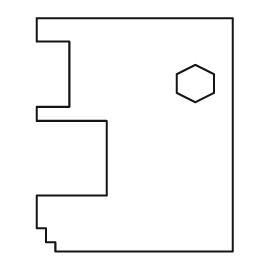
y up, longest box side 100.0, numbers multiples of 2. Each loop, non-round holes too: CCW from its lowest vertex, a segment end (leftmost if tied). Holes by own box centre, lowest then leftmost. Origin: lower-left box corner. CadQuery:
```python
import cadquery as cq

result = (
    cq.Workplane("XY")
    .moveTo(8.0, 0.0)
    .lineTo(84.0, 0.0)
    .lineTo(84.0, 100.0)
    .lineTo(0.0, 100.0)
    .lineTo(0.0, 90.0)
    .lineTo(14.0, 90.0)
    .lineTo(14.0, 62.0)
    .lineTo(0.0, 62.0)
    .lineTo(0.0, 56.0)
    .lineTo(30.0, 56.0)
    .lineTo(30.0, 24.0)
    .lineTo(0.0, 24.0)
    .lineTo(0.0, 10.0)
    .lineTo(4.0, 10.0)
    .lineTo(4.0, 4.0)
    .lineTo(8.0, 4.0)
    .close()
    .moveTo(68.0, 64.0)
    .lineTo(76.0, 68.0)
    .lineTo(76.0, 76.0)
    .lineTo(68.0, 80.0)
    .lineTo(60.0, 76.0)
    .lineTo(60.0, 68.0)
    .close()
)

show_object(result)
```